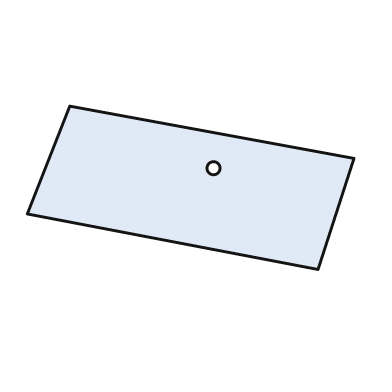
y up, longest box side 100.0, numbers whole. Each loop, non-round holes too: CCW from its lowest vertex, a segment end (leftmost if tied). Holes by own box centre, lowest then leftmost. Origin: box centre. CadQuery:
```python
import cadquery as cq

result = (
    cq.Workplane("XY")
    .moveTo(39.0, -25.0)
    .lineTo(50.0, 9.0)
    .lineTo(-37.0, 25.0)
    .lineTo(-50.0, -8.0)
    .close()
    .moveTo(7.0, 6.0)
    .circle(2.0)
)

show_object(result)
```